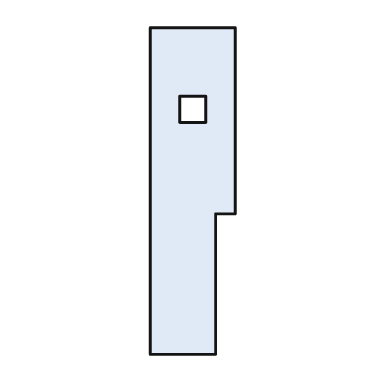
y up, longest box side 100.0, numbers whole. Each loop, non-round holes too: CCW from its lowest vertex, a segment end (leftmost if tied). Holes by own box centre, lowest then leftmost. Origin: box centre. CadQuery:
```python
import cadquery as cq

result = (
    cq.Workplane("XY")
    .moveTo(-13.0, -50.0)
    .lineTo(7.0, -50.0)
    .lineTo(7.0, -7.0)
    .lineTo(13.0, -7.0)
    .lineTo(13.0, 50.0)
    .lineTo(-13.0, 50.0)
    .close()
    .moveTo(-4.0, 21.0)
    .lineTo(4.0, 21.0)
    .lineTo(4.0, 29.0)
    .lineTo(-4.0, 29.0)
    .close()
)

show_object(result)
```